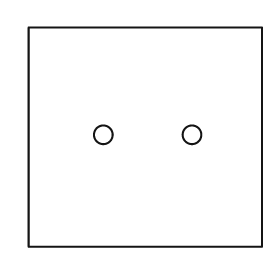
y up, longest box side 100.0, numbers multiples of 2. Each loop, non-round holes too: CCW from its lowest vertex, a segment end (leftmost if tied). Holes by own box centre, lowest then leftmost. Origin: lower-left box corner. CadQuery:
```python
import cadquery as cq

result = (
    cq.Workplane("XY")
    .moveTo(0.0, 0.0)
    .lineTo(100.0, 0.0)
    .lineTo(100.0, 94.0)
    .lineTo(0.0, 94.0)
    .close()
    .moveTo(32.0, 48.0)
    .circle(4.0)
    .moveTo(70.0, 48.0)
    .circle(4.0)
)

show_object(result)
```